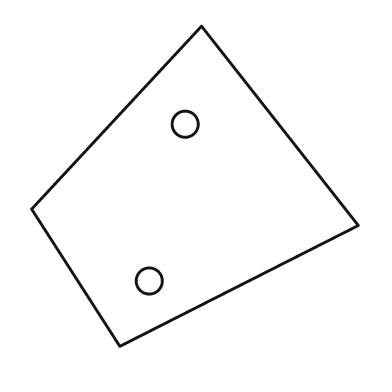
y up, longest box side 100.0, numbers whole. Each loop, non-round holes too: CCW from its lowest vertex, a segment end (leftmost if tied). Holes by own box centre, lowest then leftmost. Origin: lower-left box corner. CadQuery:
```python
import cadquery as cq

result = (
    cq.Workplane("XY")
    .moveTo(27.0, 0.0)
    .lineTo(100.0, 37.0)
    .lineTo(52.0, 98.0)
    .lineTo(0.0, 42.0)
    .close()
    .moveTo(36.0, 20.0)
    .circle(4.0)
    .moveTo(47.0, 68.0)
    .circle(4.0)
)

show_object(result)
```